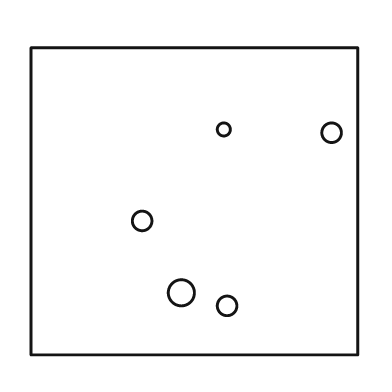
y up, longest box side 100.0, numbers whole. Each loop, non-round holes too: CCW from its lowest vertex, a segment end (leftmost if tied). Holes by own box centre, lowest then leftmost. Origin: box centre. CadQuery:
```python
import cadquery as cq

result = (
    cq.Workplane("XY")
    .moveTo(-50.0, -47.0)
    .lineTo(50.0, -47.0)
    .lineTo(50.0, 47.0)
    .lineTo(-50.0, 47.0)
    .close()
    .moveTo(10.0, -32.0)
    .circle(3.0)
    .moveTo(-4.0, -28.0)
    .circle(4.0)
    .moveTo(-16.0, -6.0)
    .circle(3.0)
    .moveTo(42.0, 21.0)
    .circle(3.0)
    .moveTo(9.0, 22.0)
    .circle(2.0)
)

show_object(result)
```